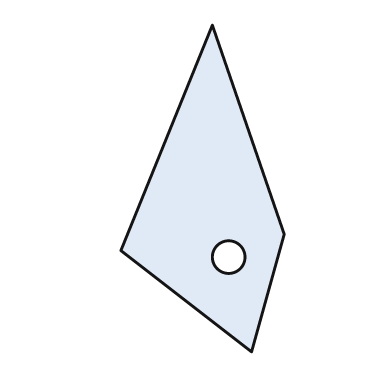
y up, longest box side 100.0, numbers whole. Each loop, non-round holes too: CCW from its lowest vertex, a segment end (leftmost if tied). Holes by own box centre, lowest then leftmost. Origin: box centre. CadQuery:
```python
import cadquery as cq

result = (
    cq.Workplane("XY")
    .moveTo(15.0, -50.0)
    .lineTo(25.0, -14.0)
    .lineTo(3.0, 50.0)
    .lineTo(-25.0, -19.0)
    .close()
    .moveTo(8.0, -21.0)
    .circle(5.0)
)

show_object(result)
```